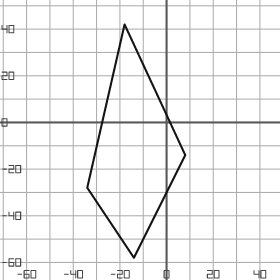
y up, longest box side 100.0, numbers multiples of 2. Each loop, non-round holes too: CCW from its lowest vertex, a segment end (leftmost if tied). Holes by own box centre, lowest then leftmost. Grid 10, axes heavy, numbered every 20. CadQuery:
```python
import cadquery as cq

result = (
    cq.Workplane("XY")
    .moveTo(-14.0, -58.0)
    .lineTo(8.0, -14.0)
    .lineTo(-18.0, 42.0)
    .lineTo(-34.0, -28.0)
    .close()
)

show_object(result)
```